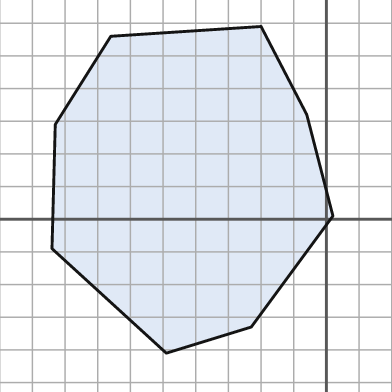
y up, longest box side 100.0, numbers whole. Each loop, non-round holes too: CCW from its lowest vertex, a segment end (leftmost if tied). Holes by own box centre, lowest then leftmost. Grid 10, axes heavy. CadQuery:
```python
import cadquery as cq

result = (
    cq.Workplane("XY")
    .moveTo(-49.0, -41.0)
    .lineTo(-23.0, -33.0)
    .lineTo(2.0, 1.0)
    .lineTo(-6.0, 32.0)
    .lineTo(-20.0, 59.0)
    .lineTo(-66.0, 56.0)
    .lineTo(-83.0, 29.0)
    .lineTo(-84.0, -9.0)
    .close()
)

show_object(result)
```